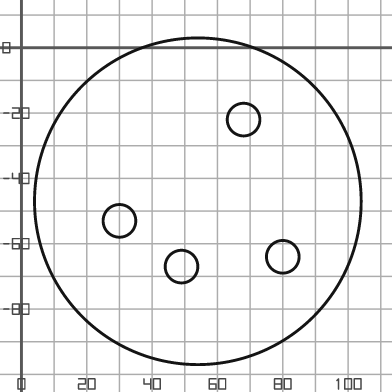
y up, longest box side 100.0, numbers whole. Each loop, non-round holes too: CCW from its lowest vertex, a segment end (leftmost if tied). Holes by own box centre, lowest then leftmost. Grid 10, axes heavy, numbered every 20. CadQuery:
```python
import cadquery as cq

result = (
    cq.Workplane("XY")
    .moveTo(54.0, -47.0)
    .circle(50.0)
    .moveTo(49.0, -67.0)
    .circle(5.0)
    .moveTo(80.0, -64.0)
    .circle(5.0)
    .moveTo(30.0, -53.0)
    .circle(5.0)
    .moveTo(68.0, -22.0)
    .circle(5.0)
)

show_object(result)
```